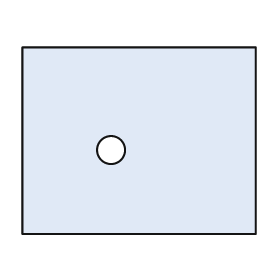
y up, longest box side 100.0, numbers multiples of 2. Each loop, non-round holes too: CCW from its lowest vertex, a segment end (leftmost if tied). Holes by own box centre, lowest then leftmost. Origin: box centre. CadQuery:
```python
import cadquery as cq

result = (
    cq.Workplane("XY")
    .moveTo(-50.0, -40.0)
    .lineTo(50.0, -40.0)
    .lineTo(50.0, 40.0)
    .lineTo(-50.0, 40.0)
    .close()
    .moveTo(-12.0, -4.0)
    .circle(6.0)
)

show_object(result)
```